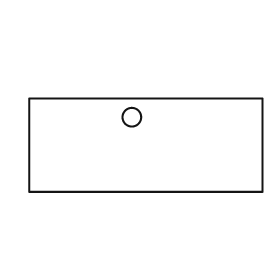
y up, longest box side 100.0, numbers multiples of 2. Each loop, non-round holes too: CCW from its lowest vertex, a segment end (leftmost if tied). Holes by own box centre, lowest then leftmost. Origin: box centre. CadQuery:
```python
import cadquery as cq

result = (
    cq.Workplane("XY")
    .moveTo(-50.0, -20.0)
    .lineTo(50.0, -20.0)
    .lineTo(50.0, 20.0)
    .lineTo(-50.0, 20.0)
    .close()
    .moveTo(-6.0, 12.0)
    .circle(4.0)
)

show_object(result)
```